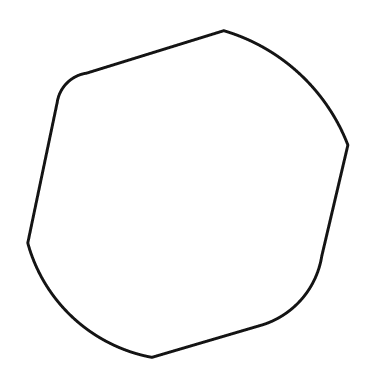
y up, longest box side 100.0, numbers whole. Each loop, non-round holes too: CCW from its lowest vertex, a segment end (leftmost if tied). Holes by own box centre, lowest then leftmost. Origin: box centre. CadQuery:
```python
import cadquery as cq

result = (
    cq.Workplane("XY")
    .moveTo(-11.0, -50.0)
    .lineTo(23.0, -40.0)
    .threePointArc((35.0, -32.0), (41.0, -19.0))
    .lineTo(49.0, 15.0)
    .threePointArc((34.0, 37.0), (11.0, 50.0))
    .lineTo(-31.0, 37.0)
    .threePointArc((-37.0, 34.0), (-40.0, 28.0))
    .lineTo(-49.0, -15.0)
    .threePointArc((-35.0, -38.0), (-11.0, -50.0))
    .close()
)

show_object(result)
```